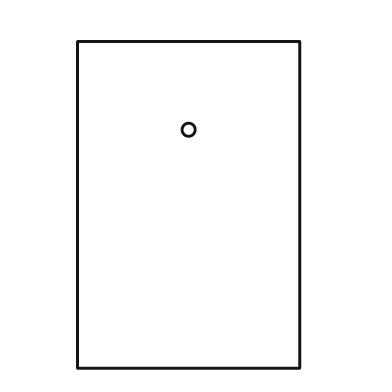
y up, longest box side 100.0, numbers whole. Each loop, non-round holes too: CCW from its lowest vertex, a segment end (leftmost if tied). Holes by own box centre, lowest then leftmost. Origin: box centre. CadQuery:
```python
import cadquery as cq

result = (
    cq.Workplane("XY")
    .moveTo(-34.0, -50.0)
    .lineTo(34.0, -50.0)
    .lineTo(34.0, 50.0)
    .lineTo(-34.0, 50.0)
    .close()
    .moveTo(0.0, 23.0)
    .circle(2.0)
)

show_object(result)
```